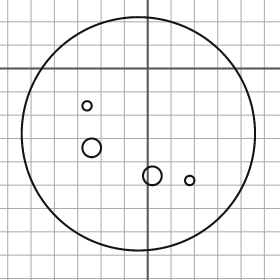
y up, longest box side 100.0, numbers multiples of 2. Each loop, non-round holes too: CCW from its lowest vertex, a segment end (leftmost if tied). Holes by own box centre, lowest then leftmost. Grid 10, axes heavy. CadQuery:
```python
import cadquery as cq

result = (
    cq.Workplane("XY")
    .moveTo(-4.0, -28.0)
    .circle(50.0)
    .moveTo(18.0, -48.0)
    .circle(2.0)
    .moveTo(2.0, -46.0)
    .circle(4.0)
    .moveTo(-24.0, -34.0)
    .circle(4.0)
    .moveTo(-26.0, -16.0)
    .circle(2.0)
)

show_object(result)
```